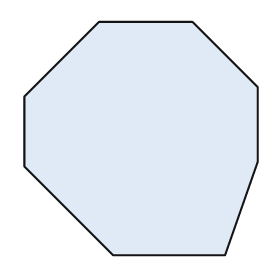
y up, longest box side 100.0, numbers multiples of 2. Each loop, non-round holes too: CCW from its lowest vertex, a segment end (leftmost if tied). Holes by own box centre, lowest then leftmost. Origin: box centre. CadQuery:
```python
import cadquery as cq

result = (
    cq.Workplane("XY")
    .moveTo(-12.0, -50.0)
    .lineTo(36.0, -50.0)
    .lineTo(50.0, -10.0)
    .lineTo(50.0, 22.0)
    .lineTo(22.0, 50.0)
    .lineTo(-18.0, 50.0)
    .lineTo(-50.0, 18.0)
    .lineTo(-50.0, -12.0)
    .close()
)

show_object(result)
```